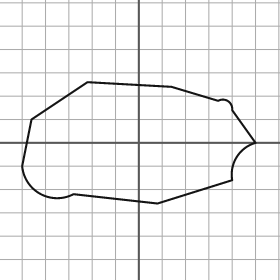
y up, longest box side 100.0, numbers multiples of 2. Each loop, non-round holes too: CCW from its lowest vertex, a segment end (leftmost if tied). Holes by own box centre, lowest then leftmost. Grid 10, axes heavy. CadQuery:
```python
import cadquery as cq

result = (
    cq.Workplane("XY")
    .moveTo(8.0, -26.0)
    .lineTo(40.0, -16.0)
    .threePointArc((42.0, -6.0), (50.0, 0.0))
    .lineTo(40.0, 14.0)
    .threePointArc((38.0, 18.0), (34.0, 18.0))
    .lineTo(14.0, 24.0)
    .lineTo(-22.0, 26.0)
    .lineTo(-46.0, 10.0)
    .lineTo(-50.0, -10.0)
    .threePointArc((-42.0, -22.0), (-28.0, -22.0))
    .close()
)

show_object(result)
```